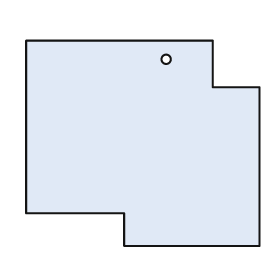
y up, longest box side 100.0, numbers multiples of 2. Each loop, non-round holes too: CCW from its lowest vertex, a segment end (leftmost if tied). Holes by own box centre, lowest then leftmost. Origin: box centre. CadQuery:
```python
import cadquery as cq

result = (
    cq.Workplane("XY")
    .moveTo(-8.0, -44.0)
    .lineTo(50.0, -44.0)
    .lineTo(50.0, 24.0)
    .lineTo(30.0, 24.0)
    .lineTo(30.0, 44.0)
    .lineTo(-50.0, 44.0)
    .lineTo(-50.0, -30.0)
    .lineTo(-8.0, -30.0)
    .close()
    .moveTo(10.0, 36.0)
    .circle(2.0)
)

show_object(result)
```